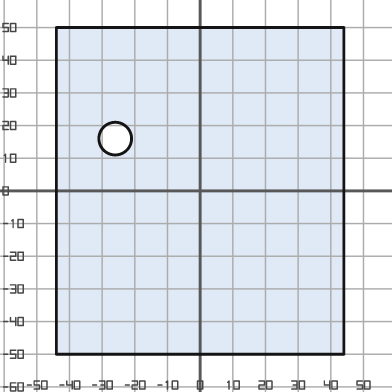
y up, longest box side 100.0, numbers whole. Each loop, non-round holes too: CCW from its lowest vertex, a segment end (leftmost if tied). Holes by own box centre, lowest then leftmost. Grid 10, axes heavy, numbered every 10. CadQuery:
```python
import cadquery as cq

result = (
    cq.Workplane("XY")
    .moveTo(-44.0, -50.0)
    .lineTo(44.0, -50.0)
    .lineTo(44.0, 50.0)
    .lineTo(-44.0, 50.0)
    .close()
    .moveTo(-26.0, 16.0)
    .circle(5.0)
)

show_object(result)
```